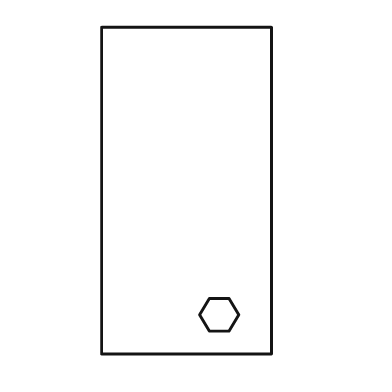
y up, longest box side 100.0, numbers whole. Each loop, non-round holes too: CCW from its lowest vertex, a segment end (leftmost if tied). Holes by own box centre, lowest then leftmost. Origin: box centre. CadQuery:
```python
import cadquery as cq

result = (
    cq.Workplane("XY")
    .moveTo(-26.0, -50.0)
    .lineTo(26.0, -50.0)
    .lineTo(26.0, 50.0)
    .lineTo(-26.0, 50.0)
    .close()
    .moveTo(7.0, -43.0)
    .lineTo(13.0, -43.0)
    .lineTo(16.0, -38.0)
    .lineTo(13.0, -33.0)
    .lineTo(7.0, -33.0)
    .lineTo(4.0, -38.0)
    .close()
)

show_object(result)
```